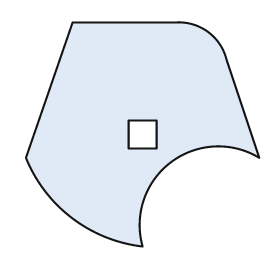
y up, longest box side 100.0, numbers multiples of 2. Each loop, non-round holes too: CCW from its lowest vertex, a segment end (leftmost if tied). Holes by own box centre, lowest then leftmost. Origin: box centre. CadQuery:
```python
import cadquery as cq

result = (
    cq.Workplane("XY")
    .moveTo(0.0, -48.0)
    .threePointArc((12.0, -12.0), (50.0, -10.0))
    .lineTo(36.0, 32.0)
    .threePointArc((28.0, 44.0), (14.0, 48.0))
    .lineTo(-30.0, 48.0)
    .lineTo(-50.0, -10.0)
    .threePointArc((-30.0, -36.0), (0.0, -48.0))
    .close()
    .moveTo(-6.0, -6.0)
    .lineTo(6.0, -6.0)
    .lineTo(6.0, 6.0)
    .lineTo(-6.0, 6.0)
    .close()
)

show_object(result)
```